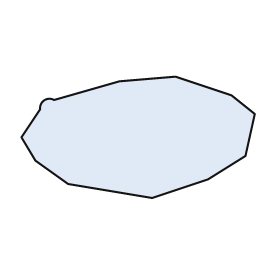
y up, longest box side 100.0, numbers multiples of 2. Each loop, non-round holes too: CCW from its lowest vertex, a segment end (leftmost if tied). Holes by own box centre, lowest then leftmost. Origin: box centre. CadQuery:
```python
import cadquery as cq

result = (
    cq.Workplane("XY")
    .moveTo(6.0, -26.0)
    .lineTo(30.0, -18.0)
    .lineTo(46.0, -8.0)
    .lineTo(50.0, 10.0)
    .lineTo(40.0, 18.0)
    .lineTo(16.0, 26.0)
    .lineTo(-8.0, 24.0)
    .lineTo(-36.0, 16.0)
    .threePointArc((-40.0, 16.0), (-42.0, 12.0))
    .lineTo(-50.0, 0.0)
    .lineTo(-44.0, -10.0)
    .lineTo(-30.0, -20.0)
    .close()
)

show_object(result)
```